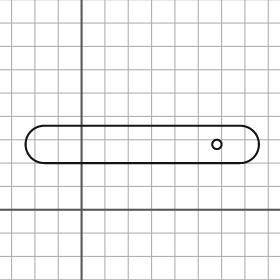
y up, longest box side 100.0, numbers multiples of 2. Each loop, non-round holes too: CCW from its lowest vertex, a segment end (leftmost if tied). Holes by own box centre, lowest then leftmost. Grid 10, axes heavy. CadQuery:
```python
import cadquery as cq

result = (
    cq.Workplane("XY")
    .moveTo(-16.0, 20.0)
    .lineTo(68.0, 20.0)
    .threePointArc((76.0, 28.0), (68.0, 36.0))
    .lineTo(-16.0, 36.0)
    .threePointArc((-24.0, 28.0), (-16.0, 20.0))
    .close()
    .moveTo(58.0, 28.0)
    .circle(2.0)
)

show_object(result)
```